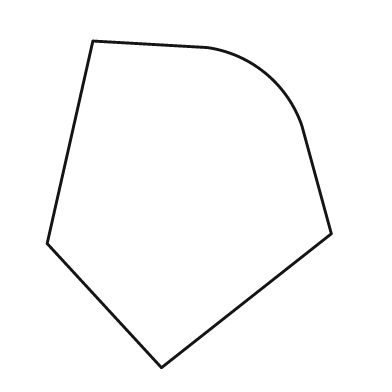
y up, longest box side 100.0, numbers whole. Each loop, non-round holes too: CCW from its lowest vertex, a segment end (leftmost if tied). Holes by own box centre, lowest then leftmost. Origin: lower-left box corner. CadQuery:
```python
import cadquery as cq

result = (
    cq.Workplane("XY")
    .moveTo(35.0, 0.0)
    .lineTo(87.0, 41.0)
    .lineTo(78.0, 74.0)
    .threePointArc((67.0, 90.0), (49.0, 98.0))
    .lineTo(14.0, 100.0)
    .lineTo(0.0, 38.0)
    .close()
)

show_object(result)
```